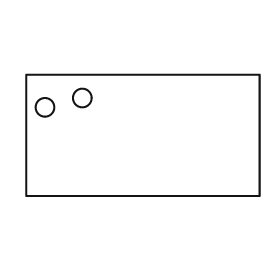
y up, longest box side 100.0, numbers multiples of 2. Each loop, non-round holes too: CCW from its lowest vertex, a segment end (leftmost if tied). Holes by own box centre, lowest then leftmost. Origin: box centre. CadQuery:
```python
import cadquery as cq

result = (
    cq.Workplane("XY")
    .moveTo(-50.0, -26.0)
    .lineTo(50.0, -26.0)
    .lineTo(50.0, 26.0)
    .lineTo(-50.0, 26.0)
    .close()
    .moveTo(-42.0, 12.0)
    .circle(4.0)
    .moveTo(-26.0, 16.0)
    .circle(4.0)
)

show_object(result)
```